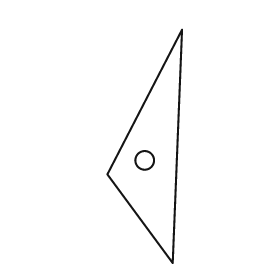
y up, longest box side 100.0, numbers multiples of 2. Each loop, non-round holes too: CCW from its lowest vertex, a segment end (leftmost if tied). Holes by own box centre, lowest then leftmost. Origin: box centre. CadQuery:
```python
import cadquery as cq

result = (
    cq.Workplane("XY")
    .moveTo(12.0, -50.0)
    .lineTo(16.0, 50.0)
    .lineTo(-16.0, -12.0)
    .close()
    .moveTo(0.0, -6.0)
    .circle(4.0)
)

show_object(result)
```